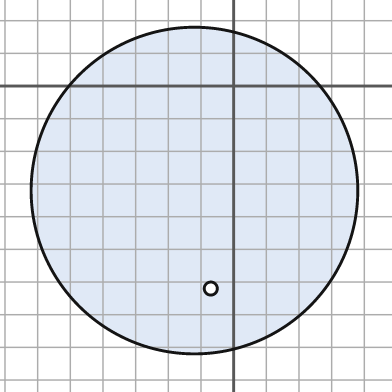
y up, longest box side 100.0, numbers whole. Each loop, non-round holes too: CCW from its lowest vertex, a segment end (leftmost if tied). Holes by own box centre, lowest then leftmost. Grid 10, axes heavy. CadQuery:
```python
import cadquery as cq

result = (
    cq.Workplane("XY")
    .moveTo(-12.0, -32.0)
    .circle(50.0)
    .moveTo(-7.0, -62.0)
    .circle(2.0)
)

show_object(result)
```